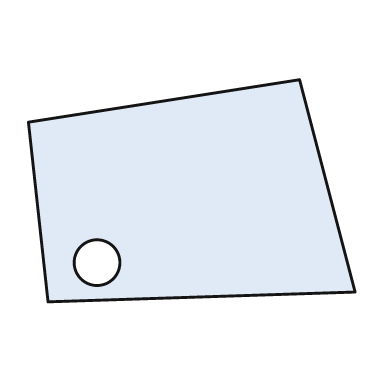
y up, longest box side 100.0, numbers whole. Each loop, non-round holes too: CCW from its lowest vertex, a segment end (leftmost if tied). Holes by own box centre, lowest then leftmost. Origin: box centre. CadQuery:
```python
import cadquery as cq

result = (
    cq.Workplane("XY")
    .moveTo(-44.0, -34.0)
    .lineTo(50.0, -31.0)
    .lineTo(33.0, 34.0)
    .lineTo(-50.0, 21.0)
    .close()
    .moveTo(-29.0, -22.0)
    .circle(7.0)
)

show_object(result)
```